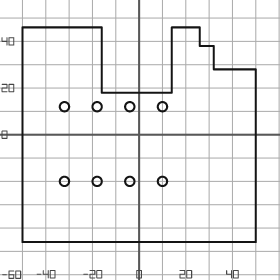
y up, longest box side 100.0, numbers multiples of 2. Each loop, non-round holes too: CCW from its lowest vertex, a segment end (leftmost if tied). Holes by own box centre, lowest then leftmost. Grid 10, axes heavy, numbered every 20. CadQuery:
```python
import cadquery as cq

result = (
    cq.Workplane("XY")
    .moveTo(-50.0, -46.0)
    .lineTo(50.0, -46.0)
    .lineTo(50.0, 28.0)
    .lineTo(32.0, 28.0)
    .lineTo(32.0, 38.0)
    .lineTo(26.0, 38.0)
    .lineTo(26.0, 46.0)
    .lineTo(14.0, 46.0)
    .lineTo(14.0, 18.0)
    .lineTo(-16.0, 18.0)
    .lineTo(-16.0, 46.0)
    .lineTo(-50.0, 46.0)
    .close()
    .moveTo(-32.0, -20.0)
    .circle(2.0)
    .moveTo(-18.0, -20.0)
    .circle(2.0)
    .moveTo(-4.0, -20.0)
    .circle(2.0)
    .moveTo(10.0, -20.0)
    .circle(2.0)
    .moveTo(-32.0, 12.0)
    .circle(2.0)
    .moveTo(-18.0, 12.0)
    .circle(2.0)
    .moveTo(-4.0, 12.0)
    .circle(2.0)
    .moveTo(10.0, 12.0)
    .circle(2.0)
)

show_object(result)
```